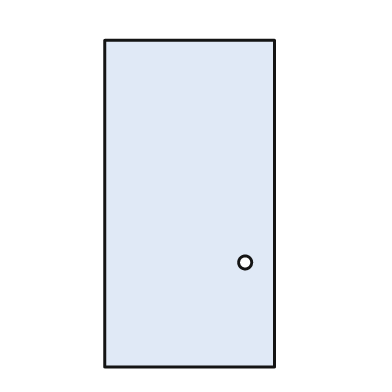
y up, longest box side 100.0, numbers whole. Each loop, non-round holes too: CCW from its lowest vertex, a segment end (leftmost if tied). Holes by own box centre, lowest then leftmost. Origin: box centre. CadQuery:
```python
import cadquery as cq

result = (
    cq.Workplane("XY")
    .moveTo(-26.0, -50.0)
    .lineTo(26.0, -50.0)
    .lineTo(26.0, 50.0)
    .lineTo(-26.0, 50.0)
    .close()
    .moveTo(17.0, -18.0)
    .circle(2.0)
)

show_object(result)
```